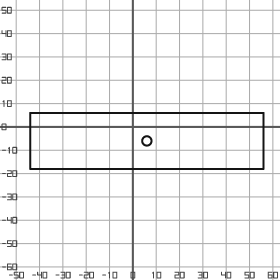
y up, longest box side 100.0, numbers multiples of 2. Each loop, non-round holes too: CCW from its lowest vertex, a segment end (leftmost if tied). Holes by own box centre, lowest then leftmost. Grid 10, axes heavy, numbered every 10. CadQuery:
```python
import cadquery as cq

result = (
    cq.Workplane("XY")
    .moveTo(-44.0, -18.0)
    .lineTo(56.0, -18.0)
    .lineTo(56.0, 6.0)
    .lineTo(-44.0, 6.0)
    .close()
    .moveTo(6.0, -6.0)
    .circle(2.0)
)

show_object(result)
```